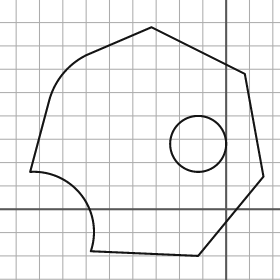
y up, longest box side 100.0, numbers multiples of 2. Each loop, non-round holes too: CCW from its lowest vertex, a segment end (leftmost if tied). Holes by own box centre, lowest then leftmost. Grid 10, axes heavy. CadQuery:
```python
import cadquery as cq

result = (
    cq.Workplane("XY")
    .moveTo(-12.0, -20.0)
    .lineTo(16.0, 14.0)
    .lineTo(8.0, 58.0)
    .lineTo(-32.0, 78.0)
    .lineTo(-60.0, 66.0)
    .threePointArc((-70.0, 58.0), (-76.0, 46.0))
    .lineTo(-84.0, 16.0)
    .threePointArc((-62.0, 6.0), (-58.0, -18.0))
    .close()
    .moveTo(-12.0, 28.0)
    .circle(12.0)
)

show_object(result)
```